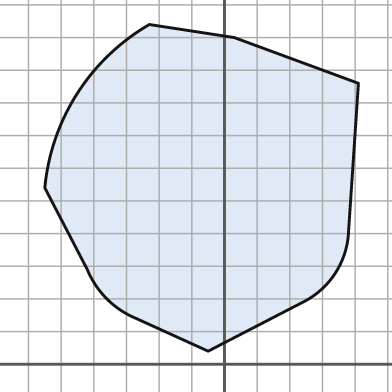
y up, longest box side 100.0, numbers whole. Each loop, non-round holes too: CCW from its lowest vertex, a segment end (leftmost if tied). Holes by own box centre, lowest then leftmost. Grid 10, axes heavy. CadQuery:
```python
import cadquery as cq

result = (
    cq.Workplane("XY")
    .moveTo(-5.0, 4.0)
    .lineTo(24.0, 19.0)
    .threePointArc((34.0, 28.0), (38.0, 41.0))
    .lineTo(41.0, 86.0)
    .lineTo(3.0, 100.0)
    .lineTo(-23.0, 104.0)
    .threePointArc((-45.0, 83.0), (-55.0, 54.0))
    .lineTo(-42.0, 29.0)
    .threePointArc((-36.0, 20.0), (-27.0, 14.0))
    .close()
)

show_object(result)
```